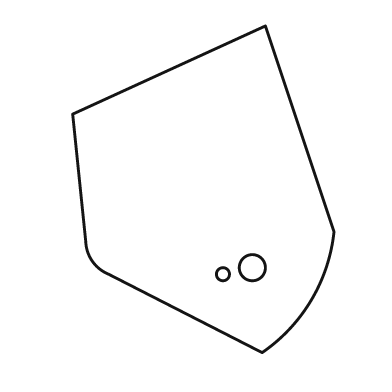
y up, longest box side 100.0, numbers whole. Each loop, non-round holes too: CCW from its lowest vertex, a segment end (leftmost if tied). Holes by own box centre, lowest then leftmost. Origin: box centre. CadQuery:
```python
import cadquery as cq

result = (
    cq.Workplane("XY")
    .moveTo(18.0, -50.0)
    .threePointArc((33.0, -34.0), (40.0, -13.0))
    .lineTo(19.0, 50.0)
    .lineTo(-40.0, 23.0)
    .lineTo(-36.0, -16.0)
    .threePointArc((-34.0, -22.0), (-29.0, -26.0))
    .close()
    .moveTo(6.0, -26.0)
    .circle(2.0)
    .moveTo(15.0, -24.0)
    .circle(4.0)
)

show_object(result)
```